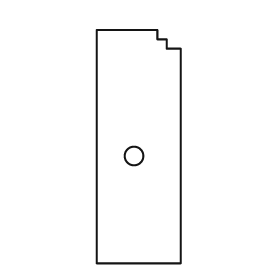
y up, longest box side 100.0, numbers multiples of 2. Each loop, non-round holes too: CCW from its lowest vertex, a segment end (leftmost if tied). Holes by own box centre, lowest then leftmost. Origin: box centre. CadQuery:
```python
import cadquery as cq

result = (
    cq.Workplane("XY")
    .moveTo(-18.0, -50.0)
    .lineTo(18.0, -50.0)
    .lineTo(18.0, 42.0)
    .lineTo(12.0, 42.0)
    .lineTo(12.0, 46.0)
    .lineTo(8.0, 46.0)
    .lineTo(8.0, 50.0)
    .lineTo(-18.0, 50.0)
    .close()
    .moveTo(-2.0, -4.0)
    .circle(4.0)
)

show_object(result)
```